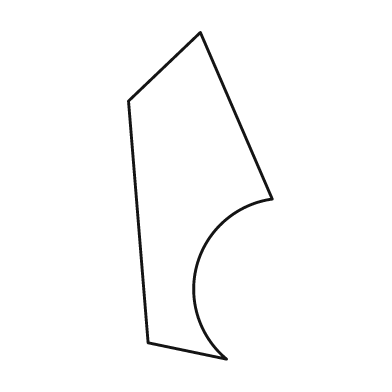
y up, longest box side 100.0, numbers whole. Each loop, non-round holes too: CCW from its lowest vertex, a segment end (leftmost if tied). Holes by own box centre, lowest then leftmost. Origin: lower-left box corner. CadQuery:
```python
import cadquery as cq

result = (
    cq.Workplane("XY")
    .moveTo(30.0, 0.0)
    .threePointArc((21.0, 29.0), (44.0, 49.0))
    .lineTo(22.0, 100.0)
    .lineTo(0.0, 79.0)
    .lineTo(6.0, 5.0)
    .close()
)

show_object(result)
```